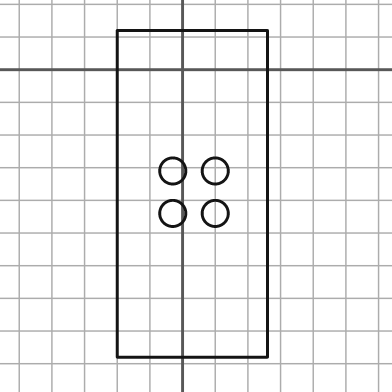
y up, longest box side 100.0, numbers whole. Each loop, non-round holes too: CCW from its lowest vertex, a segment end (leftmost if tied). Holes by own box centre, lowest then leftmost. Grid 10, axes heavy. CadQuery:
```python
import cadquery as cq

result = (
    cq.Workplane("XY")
    .moveTo(-20.0, -88.0)
    .lineTo(26.0, -88.0)
    .lineTo(26.0, 12.0)
    .lineTo(-20.0, 12.0)
    .close()
    .moveTo(-3.0, -44.0)
    .circle(4.0)
    .moveTo(10.0, -44.0)
    .circle(4.0)
    .moveTo(-3.0, -31.0)
    .circle(4.0)
    .moveTo(10.0, -31.0)
    .circle(4.0)
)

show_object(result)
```